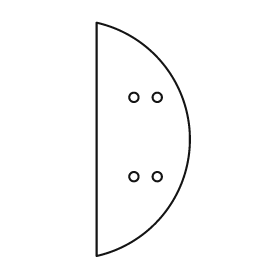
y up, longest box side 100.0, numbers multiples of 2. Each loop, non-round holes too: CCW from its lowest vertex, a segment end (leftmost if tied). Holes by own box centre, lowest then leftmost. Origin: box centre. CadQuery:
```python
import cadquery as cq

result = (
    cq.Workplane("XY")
    .moveTo(-20.0, -50.0)
    .threePointArc((20.0, 0.0), (-20.0, 50.0))
    .close()
    .moveTo(-4.0, -16.0)
    .circle(2.0)
    .moveTo(6.0, -16.0)
    .circle(2.0)
    .moveTo(-4.0, 18.0)
    .circle(2.0)
    .moveTo(6.0, 18.0)
    .circle(2.0)
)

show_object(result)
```